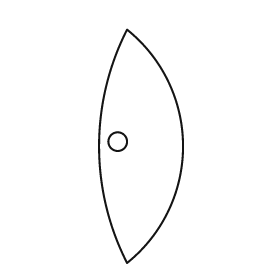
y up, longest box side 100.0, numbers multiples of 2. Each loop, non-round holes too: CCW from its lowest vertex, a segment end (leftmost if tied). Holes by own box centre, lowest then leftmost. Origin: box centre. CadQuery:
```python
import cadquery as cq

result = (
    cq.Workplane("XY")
    .moveTo(-6.0, -50.0)
    .threePointArc((18.0, 0.0), (-6.0, 50.0))
    .threePointArc((-18.0, 0.0), (-6.0, -50.0))
    .close()
    .moveTo(-10.0, 2.0)
    .circle(4.0)
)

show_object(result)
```